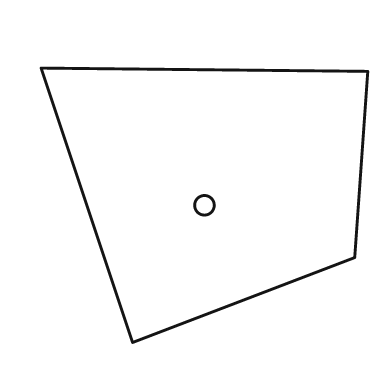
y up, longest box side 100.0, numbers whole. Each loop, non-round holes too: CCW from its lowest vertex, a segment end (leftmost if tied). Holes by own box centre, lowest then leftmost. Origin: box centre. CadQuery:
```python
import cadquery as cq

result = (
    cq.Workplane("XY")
    .moveTo(-22.0, -42.0)
    .lineTo(46.0, -16.0)
    .lineTo(50.0, 41.0)
    .lineTo(-50.0, 42.0)
    .close()
    .moveTo(0.0, 0.0)
    .circle(3.0)
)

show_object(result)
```